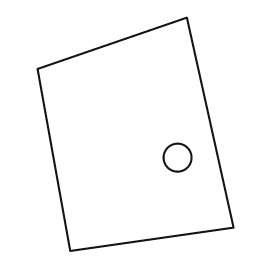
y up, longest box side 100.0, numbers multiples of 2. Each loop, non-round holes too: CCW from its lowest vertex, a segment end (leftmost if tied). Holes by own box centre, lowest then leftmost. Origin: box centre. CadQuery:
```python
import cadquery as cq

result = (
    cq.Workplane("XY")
    .moveTo(-28.0, -50.0)
    .lineTo(42.0, -40.0)
    .lineTo(22.0, 50.0)
    .lineTo(-42.0, 28.0)
    .close()
    .moveTo(18.0, -10.0)
    .circle(6.0)
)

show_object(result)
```